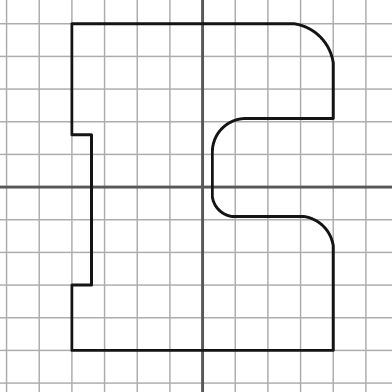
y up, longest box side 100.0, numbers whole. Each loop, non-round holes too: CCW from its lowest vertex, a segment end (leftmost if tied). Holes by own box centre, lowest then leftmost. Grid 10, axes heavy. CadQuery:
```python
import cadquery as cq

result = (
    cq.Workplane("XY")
    .moveTo(-40.0, -50.0)
    .lineTo(40.0, -50.0)
    .lineTo(40.0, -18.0)
    .threePointArc((37.0, -12.0), (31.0, -9.0))
    .lineTo(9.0, -9.0)
    .threePointArc((5.0, -7.0), (3.0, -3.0))
    .lineTo(3.0, 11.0)
    .threePointArc((6.0, 18.0), (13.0, 21.0))
    .lineTo(40.0, 21.0)
    .lineTo(40.0, 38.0)
    .threePointArc((36.0, 46.0), (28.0, 50.0))
    .lineTo(-40.0, 50.0)
    .lineTo(-40.0, 16.0)
    .lineTo(-34.0, 16.0)
    .lineTo(-34.0, -30.0)
    .lineTo(-40.0, -30.0)
    .close()
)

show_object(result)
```